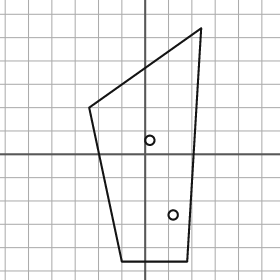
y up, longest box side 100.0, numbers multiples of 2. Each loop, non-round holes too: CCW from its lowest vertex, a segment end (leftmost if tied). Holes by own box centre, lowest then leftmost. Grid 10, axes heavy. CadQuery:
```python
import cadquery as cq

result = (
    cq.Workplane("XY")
    .moveTo(-10.0, -46.0)
    .lineTo(18.0, -46.0)
    .lineTo(24.0, 54.0)
    .lineTo(-24.0, 20.0)
    .close()
    .moveTo(12.0, -26.0)
    .circle(2.0)
    .moveTo(2.0, 6.0)
    .circle(2.0)
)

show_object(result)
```